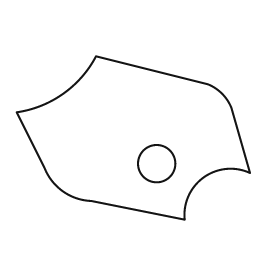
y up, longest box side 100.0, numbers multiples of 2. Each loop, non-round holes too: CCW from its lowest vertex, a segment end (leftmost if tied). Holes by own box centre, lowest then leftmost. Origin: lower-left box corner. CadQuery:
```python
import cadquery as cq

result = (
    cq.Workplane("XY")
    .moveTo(72.0, 0.0)
    .threePointArc((80.0, 18.0), (100.0, 20.0))
    .lineTo(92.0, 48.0)
    .threePointArc((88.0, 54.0), (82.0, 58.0))
    .lineTo(34.0, 70.0)
    .threePointArc((20.0, 54.0), (0.0, 46.0))
    .lineTo(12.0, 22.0)
    .threePointArc((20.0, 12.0), (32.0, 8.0))
    .close()
    .moveTo(60.0, 24.0)
    .circle(8.0)
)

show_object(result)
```